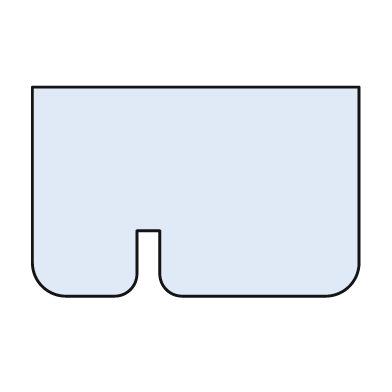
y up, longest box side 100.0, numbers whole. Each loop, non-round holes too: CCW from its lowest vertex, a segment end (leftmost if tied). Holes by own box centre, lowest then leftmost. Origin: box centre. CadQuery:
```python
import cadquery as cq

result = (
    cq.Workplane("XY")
    .moveTo(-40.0, -32.0)
    .lineTo(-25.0, -32.0)
    .threePointArc((-20.0, -30.0), (-18.0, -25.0))
    .lineTo(-18.0, -12.0)
    .lineTo(-11.0, -12.0)
    .lineTo(-11.0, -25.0)
    .threePointArc((-9.0, -30.0), (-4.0, -32.0))
    .lineTo(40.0, -32.0)
    .threePointArc((47.0, -29.0), (50.0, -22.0))
    .lineTo(50.0, 32.0)
    .lineTo(-50.0, 32.0)
    .lineTo(-50.0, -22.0)
    .threePointArc((-47.0, -29.0), (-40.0, -32.0))
    .close()
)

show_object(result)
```